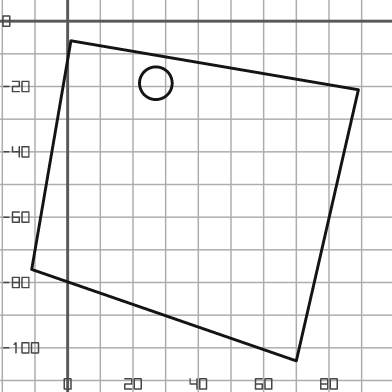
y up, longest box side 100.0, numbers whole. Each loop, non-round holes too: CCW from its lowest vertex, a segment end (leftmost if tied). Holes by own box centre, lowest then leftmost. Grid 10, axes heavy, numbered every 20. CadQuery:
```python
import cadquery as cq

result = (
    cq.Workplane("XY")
    .moveTo(70.0, -104.0)
    .lineTo(89.0, -21.0)
    .lineTo(1.0, -6.0)
    .lineTo(-11.0, -76.0)
    .close()
    .moveTo(27.0, -19.0)
    .circle(5.0)
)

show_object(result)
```